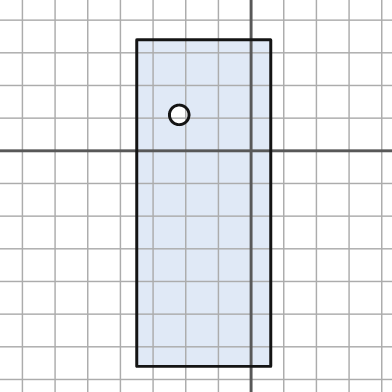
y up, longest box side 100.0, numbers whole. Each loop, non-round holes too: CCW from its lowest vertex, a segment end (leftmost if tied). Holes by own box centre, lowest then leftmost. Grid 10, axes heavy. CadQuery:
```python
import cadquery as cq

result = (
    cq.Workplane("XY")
    .moveTo(-35.0, -66.0)
    .lineTo(6.0, -66.0)
    .lineTo(6.0, 34.0)
    .lineTo(-35.0, 34.0)
    .close()
    .moveTo(-22.0, 11.0)
    .circle(3.0)
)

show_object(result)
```